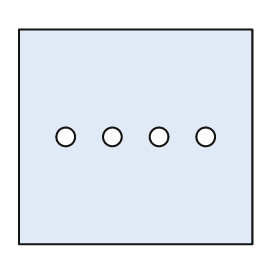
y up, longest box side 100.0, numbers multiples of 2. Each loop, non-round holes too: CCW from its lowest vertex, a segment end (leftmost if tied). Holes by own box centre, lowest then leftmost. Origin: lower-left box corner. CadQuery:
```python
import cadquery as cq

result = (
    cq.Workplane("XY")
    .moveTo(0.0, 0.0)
    .lineTo(100.0, 0.0)
    .lineTo(100.0, 92.0)
    .lineTo(0.0, 92.0)
    .close()
    .moveTo(20.0, 46.0)
    .circle(4.0)
    .moveTo(40.0, 46.0)
    .circle(4.0)
    .moveTo(60.0, 46.0)
    .circle(4.0)
    .moveTo(80.0, 46.0)
    .circle(4.0)
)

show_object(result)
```